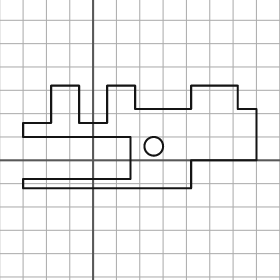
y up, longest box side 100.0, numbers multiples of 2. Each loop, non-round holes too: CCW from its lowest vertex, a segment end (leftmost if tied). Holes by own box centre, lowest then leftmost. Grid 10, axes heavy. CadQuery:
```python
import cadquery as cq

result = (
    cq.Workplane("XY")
    .moveTo(-30.0, -12.0)
    .lineTo(42.0, -12.0)
    .lineTo(42.0, 0.0)
    .lineTo(70.0, 0.0)
    .lineTo(70.0, 22.0)
    .lineTo(62.0, 22.0)
    .lineTo(62.0, 32.0)
    .lineTo(42.0, 32.0)
    .lineTo(42.0, 22.0)
    .lineTo(18.0, 22.0)
    .lineTo(18.0, 32.0)
    .lineTo(6.0, 32.0)
    .lineTo(6.0, 16.0)
    .lineTo(-6.0, 16.0)
    .lineTo(-6.0, 32.0)
    .lineTo(-18.0, 32.0)
    .lineTo(-18.0, 16.0)
    .lineTo(-30.0, 16.0)
    .lineTo(-30.0, 10.0)
    .lineTo(16.0, 10.0)
    .lineTo(16.0, -8.0)
    .lineTo(-30.0, -8.0)
    .close()
    .moveTo(26.0, 6.0)
    .circle(4.0)
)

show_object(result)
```